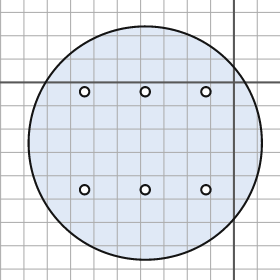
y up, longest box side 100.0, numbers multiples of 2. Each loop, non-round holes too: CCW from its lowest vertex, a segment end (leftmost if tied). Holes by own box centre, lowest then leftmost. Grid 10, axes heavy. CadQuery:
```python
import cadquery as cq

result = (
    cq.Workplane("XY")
    .moveTo(-38.0, -26.0)
    .circle(50.0)
    .moveTo(-64.0, -46.0)
    .circle(2.0)
    .moveTo(-38.0, -46.0)
    .circle(2.0)
    .moveTo(-12.0, -46.0)
    .circle(2.0)
    .moveTo(-64.0, -4.0)
    .circle(2.0)
    .moveTo(-38.0, -4.0)
    .circle(2.0)
    .moveTo(-12.0, -4.0)
    .circle(2.0)
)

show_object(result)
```